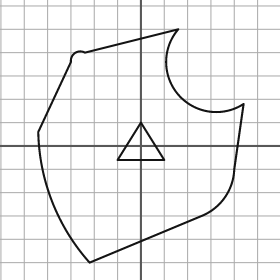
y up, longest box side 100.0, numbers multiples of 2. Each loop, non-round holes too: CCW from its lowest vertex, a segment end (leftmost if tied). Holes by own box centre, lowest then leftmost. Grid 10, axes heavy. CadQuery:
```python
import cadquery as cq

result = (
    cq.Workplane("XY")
    .moveTo(-22.0, -50.0)
    .lineTo(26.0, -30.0)
    .threePointArc((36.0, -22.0), (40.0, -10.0))
    .lineTo(44.0, 18.0)
    .threePointArc((16.0, 22.0), (16.0, 50.0))
    .lineTo(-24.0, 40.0)
    .threePointArc((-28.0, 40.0), (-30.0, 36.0))
    .lineTo(-44.0, 6.0)
    .threePointArc((-38.0, -24.0), (-22.0, -50.0))
    .close()
    .moveTo(-10.0, -6.0)
    .lineTo(10.0, -6.0)
    .lineTo(0.0, 10.0)
    .close()
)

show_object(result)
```